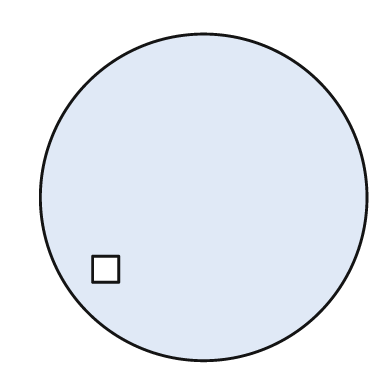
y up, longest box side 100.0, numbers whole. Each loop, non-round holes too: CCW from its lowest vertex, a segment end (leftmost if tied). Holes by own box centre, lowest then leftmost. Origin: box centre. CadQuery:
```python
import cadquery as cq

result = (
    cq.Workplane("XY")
    .moveTo(0.0, 0.0)
    .circle(50.0)
    .moveTo(-34.0, -26.0)
    .lineTo(-26.0, -26.0)
    .lineTo(-26.0, -18.0)
    .lineTo(-34.0, -18.0)
    .close()
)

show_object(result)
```